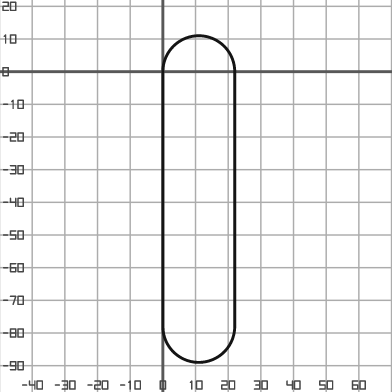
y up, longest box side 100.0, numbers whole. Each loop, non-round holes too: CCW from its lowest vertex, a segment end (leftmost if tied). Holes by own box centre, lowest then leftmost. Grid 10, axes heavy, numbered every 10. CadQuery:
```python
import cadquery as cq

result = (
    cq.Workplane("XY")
    .moveTo(0.0, -78.0)
    .threePointArc((11.0, -89.0), (22.0, -78.0))
    .lineTo(22.0, 0.0)
    .threePointArc((11.0, 11.0), (0.0, 0.0))
    .close()
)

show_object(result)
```